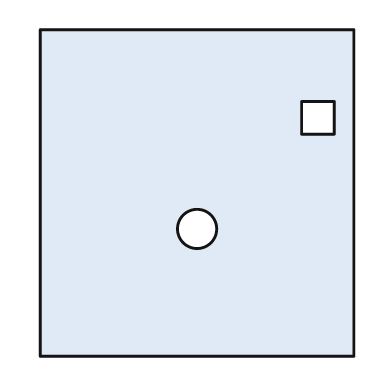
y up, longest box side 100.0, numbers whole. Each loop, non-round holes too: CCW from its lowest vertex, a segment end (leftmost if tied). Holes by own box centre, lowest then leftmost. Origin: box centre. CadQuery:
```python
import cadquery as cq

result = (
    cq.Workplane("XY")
    .moveTo(-48.0, -50.0)
    .lineTo(48.0, -50.0)
    .lineTo(48.0, 50.0)
    .lineTo(-48.0, 50.0)
    .close()
    .moveTo(0.0, -11.0)
    .circle(6.0)
    .moveTo(32.0, 18.0)
    .lineTo(42.0, 18.0)
    .lineTo(42.0, 28.0)
    .lineTo(32.0, 28.0)
    .close()
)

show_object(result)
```